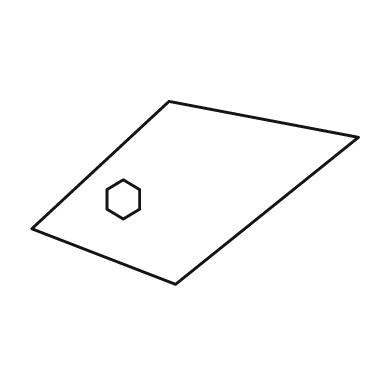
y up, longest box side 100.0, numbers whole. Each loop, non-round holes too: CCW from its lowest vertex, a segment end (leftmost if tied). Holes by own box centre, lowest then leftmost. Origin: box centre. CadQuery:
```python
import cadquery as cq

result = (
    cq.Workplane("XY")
    .moveTo(-6.0, -28.0)
    .lineTo(50.0, 17.0)
    .lineTo(-8.0, 28.0)
    .lineTo(-50.0, -11.0)
    .close()
    .moveTo(-22.0, -8.0)
    .lineTo(-17.0, -5.0)
    .lineTo(-17.0, 1.0)
    .lineTo(-22.0, 4.0)
    .lineTo(-27.0, 1.0)
    .lineTo(-27.0, -5.0)
    .close()
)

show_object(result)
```